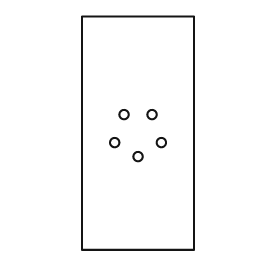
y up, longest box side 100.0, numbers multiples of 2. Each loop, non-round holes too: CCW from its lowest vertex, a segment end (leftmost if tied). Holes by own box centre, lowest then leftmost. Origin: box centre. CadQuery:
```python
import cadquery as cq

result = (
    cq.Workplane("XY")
    .moveTo(-24.0, -50.0)
    .lineTo(24.0, -50.0)
    .lineTo(24.0, 50.0)
    .lineTo(-24.0, 50.0)
    .close()
    .moveTo(0.0, -10.0)
    .circle(2.0)
    .moveTo(-10.0, -4.0)
    .circle(2.0)
    .moveTo(10.0, -4.0)
    .circle(2.0)
    .moveTo(-6.0, 8.0)
    .circle(2.0)
    .moveTo(6.0, 8.0)
    .circle(2.0)
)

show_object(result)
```